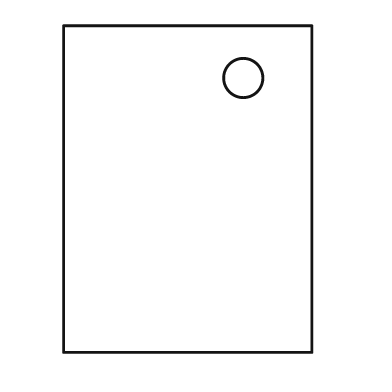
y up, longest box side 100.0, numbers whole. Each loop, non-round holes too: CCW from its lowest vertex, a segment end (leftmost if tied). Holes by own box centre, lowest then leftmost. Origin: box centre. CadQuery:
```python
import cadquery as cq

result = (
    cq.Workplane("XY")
    .moveTo(-38.0, -50.0)
    .lineTo(38.0, -50.0)
    .lineTo(38.0, 50.0)
    .lineTo(-38.0, 50.0)
    .close()
    .moveTo(17.0, 34.0)
    .circle(6.0)
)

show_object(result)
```